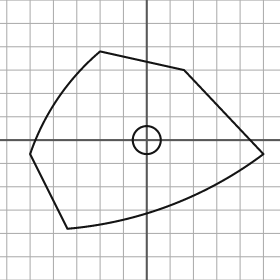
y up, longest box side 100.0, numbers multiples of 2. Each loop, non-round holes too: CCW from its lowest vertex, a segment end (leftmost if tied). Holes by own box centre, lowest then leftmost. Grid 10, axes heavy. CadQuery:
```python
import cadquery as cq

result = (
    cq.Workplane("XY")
    .moveTo(-34.0, -38.0)
    .threePointArc((10.0, -28.0), (50.0, -6.0))
    .lineTo(16.0, 30.0)
    .lineTo(-20.0, 38.0)
    .threePointArc((-38.0, 18.0), (-50.0, -6.0))
    .close()
    .moveTo(0.0, 0.0)
    .circle(6.0)
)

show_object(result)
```